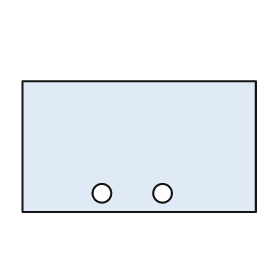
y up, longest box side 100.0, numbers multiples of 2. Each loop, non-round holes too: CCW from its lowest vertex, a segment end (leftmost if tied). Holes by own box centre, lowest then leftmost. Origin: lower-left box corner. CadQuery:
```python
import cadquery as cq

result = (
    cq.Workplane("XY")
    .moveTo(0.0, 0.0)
    .lineTo(100.0, 0.0)
    .lineTo(100.0, 56.0)
    .lineTo(0.0, 56.0)
    .close()
    .moveTo(34.0, 8.0)
    .circle(4.0)
    .moveTo(60.0, 8.0)
    .circle(4.0)
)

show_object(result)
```